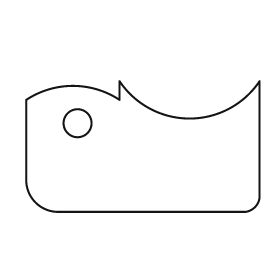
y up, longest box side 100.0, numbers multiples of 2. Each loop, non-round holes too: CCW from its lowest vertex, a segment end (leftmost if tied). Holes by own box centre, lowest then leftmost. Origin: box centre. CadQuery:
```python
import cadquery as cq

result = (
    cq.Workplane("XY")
    .moveTo(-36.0, -28.0)
    .lineTo(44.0, -28.0)
    .threePointArc((48.0, -26.0), (50.0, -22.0))
    .lineTo(50.0, 28.0)
    .threePointArc((20.0, 12.0), (-10.0, 28.0))
    .lineTo(-10.0, 20.0)
    .threePointArc((-30.0, 26.0), (-50.0, 20.0))
    .lineTo(-50.0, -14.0)
    .threePointArc((-46.0, -24.0), (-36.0, -28.0))
    .close()
    .moveTo(-28.0, 10.0)
    .circle(6.0)
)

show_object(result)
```